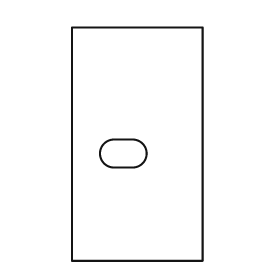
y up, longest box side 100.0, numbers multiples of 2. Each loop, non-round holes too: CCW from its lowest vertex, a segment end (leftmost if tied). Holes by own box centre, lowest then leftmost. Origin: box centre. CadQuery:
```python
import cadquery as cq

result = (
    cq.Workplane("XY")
    .moveTo(-28.0, -50.0)
    .lineTo(28.0, -50.0)
    .lineTo(28.0, 50.0)
    .lineTo(-28.0, 50.0)
    .close()
    .moveTo(-10.0, -10.0)
    .lineTo(-2.0, -10.0)
    .threePointArc((4.0, -4.0), (-2.0, 2.0))
    .lineTo(-10.0, 2.0)
    .threePointArc((-16.0, -4.0), (-10.0, -10.0))
    .close()
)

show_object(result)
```